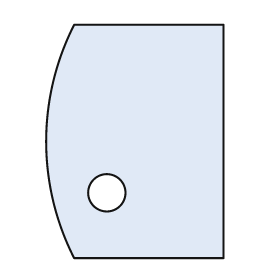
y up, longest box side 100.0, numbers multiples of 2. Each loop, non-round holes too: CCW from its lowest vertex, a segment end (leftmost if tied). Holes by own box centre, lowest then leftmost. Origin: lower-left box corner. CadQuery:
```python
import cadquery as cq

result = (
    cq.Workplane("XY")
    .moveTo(12.0, 0.0)
    .lineTo(76.0, 0.0)
    .lineTo(76.0, 100.0)
    .lineTo(12.0, 100.0)
    .threePointArc((0.0, 50.0), (12.0, 0.0))
    .close()
    .moveTo(26.0, 28.0)
    .circle(8.0)
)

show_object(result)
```